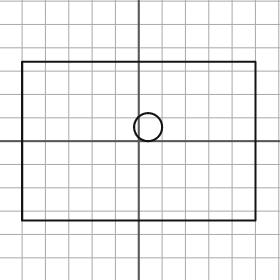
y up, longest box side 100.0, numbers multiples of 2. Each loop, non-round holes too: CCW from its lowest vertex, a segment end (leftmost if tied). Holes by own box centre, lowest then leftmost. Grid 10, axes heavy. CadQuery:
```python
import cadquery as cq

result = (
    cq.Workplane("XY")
    .moveTo(-50.0, -34.0)
    .lineTo(50.0, -34.0)
    .lineTo(50.0, 34.0)
    .lineTo(-50.0, 34.0)
    .close()
    .moveTo(4.0, 6.0)
    .circle(6.0)
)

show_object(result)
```